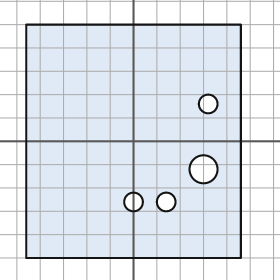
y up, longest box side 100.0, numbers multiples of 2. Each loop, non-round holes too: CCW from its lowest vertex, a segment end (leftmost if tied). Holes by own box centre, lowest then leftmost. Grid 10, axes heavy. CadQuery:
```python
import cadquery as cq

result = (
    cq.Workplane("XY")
    .moveTo(-46.0, -50.0)
    .lineTo(46.0, -50.0)
    .lineTo(46.0, 50.0)
    .lineTo(-46.0, 50.0)
    .close()
    .moveTo(0.0, -26.0)
    .circle(4.0)
    .moveTo(14.0, -26.0)
    .circle(4.0)
    .moveTo(30.0, -12.0)
    .circle(6.0)
    .moveTo(32.0, 16.0)
    .circle(4.0)
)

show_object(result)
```